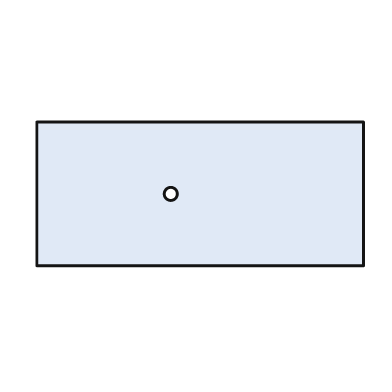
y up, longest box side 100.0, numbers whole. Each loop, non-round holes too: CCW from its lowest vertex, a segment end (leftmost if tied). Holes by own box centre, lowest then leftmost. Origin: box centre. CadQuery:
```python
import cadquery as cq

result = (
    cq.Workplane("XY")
    .moveTo(-50.0, -22.0)
    .lineTo(50.0, -22.0)
    .lineTo(50.0, 22.0)
    .lineTo(-50.0, 22.0)
    .close()
    .moveTo(-9.0, 0.0)
    .circle(2.0)
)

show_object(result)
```